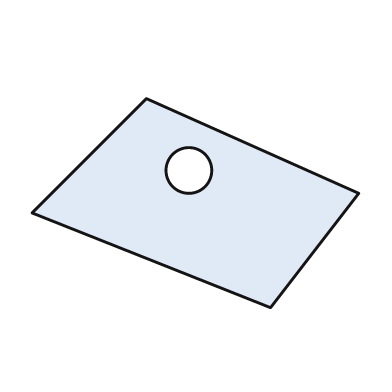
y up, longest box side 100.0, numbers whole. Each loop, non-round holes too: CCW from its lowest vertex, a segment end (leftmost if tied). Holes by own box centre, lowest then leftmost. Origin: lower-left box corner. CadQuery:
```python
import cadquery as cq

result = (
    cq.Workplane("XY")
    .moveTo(73.0, 0.0)
    .lineTo(100.0, 35.0)
    .lineTo(35.0, 64.0)
    .lineTo(0.0, 29.0)
    .close()
    .moveTo(48.0, 42.0)
    .circle(7.0)
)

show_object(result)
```